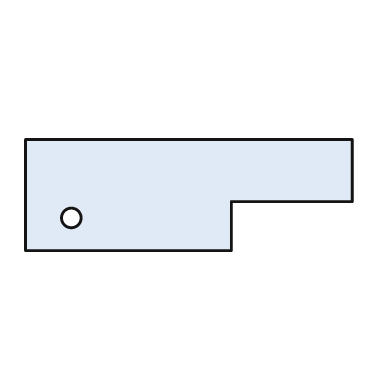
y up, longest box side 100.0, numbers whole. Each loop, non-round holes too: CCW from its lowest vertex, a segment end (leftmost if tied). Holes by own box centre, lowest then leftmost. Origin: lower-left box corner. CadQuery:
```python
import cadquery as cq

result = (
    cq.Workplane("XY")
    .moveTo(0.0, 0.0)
    .lineTo(63.0, 0.0)
    .lineTo(63.0, 15.0)
    .lineTo(100.0, 15.0)
    .lineTo(100.0, 34.0)
    .lineTo(0.0, 34.0)
    .close()
    .moveTo(14.0, 10.0)
    .circle(3.0)
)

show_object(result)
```